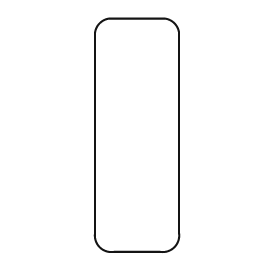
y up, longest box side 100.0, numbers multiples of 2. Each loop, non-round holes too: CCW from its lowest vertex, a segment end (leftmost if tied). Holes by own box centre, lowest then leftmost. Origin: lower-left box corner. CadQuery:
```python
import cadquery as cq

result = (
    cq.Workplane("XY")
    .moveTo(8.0, 0.0)
    .lineTo(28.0, 0.0)
    .threePointArc((34.0, 2.0), (36.0, 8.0))
    .lineTo(36.0, 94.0)
    .threePointArc((34.0, 98.0), (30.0, 100.0))
    .lineTo(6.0, 100.0)
    .threePointArc((2.0, 98.0), (0.0, 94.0))
    .lineTo(0.0, 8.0)
    .threePointArc((2.0, 2.0), (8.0, 0.0))
    .close()
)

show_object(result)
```